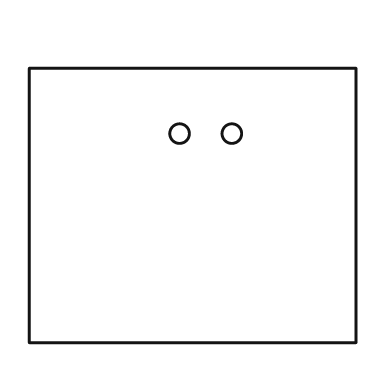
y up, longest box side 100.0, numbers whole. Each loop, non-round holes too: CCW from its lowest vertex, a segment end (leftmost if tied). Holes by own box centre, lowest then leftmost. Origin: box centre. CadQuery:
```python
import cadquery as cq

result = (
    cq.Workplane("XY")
    .moveTo(-50.0, -42.0)
    .lineTo(50.0, -42.0)
    .lineTo(50.0, 42.0)
    .lineTo(-50.0, 42.0)
    .close()
    .moveTo(-4.0, 22.0)
    .circle(3.0)
    .moveTo(12.0, 22.0)
    .circle(3.0)
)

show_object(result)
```